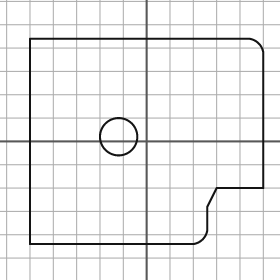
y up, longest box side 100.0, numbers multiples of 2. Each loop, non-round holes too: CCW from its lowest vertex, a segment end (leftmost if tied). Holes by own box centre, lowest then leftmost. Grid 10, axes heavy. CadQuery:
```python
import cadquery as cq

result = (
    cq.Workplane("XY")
    .moveTo(-50.0, -44.0)
    .lineTo(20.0, -44.0)
    .threePointArc((24.0, -42.0), (26.0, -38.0))
    .lineTo(26.0, -28.0)
    .lineTo(30.0, -20.0)
    .lineTo(50.0, -20.0)
    .lineTo(50.0, 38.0)
    .threePointArc((48.0, 42.0), (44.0, 44.0))
    .lineTo(-50.0, 44.0)
    .close()
    .moveTo(-12.0, 2.0)
    .circle(8.0)
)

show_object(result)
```